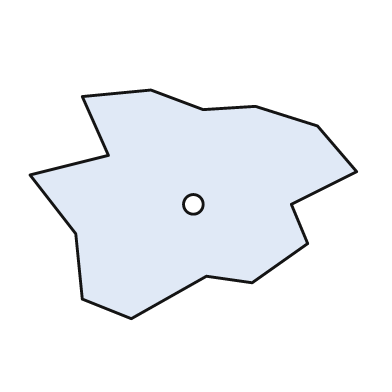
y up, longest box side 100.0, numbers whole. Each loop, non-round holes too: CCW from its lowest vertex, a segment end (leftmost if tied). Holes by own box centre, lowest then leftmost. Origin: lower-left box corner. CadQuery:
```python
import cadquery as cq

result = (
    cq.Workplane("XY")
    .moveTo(31.0, 0.0)
    .lineTo(54.0, 13.0)
    .lineTo(68.0, 11.0)
    .lineTo(85.0, 23.0)
    .lineTo(80.0, 35.0)
    .lineTo(100.0, 45.0)
    .lineTo(88.0, 59.0)
    .lineTo(69.0, 65.0)
    .lineTo(53.0, 64.0)
    .lineTo(37.0, 70.0)
    .lineTo(16.0, 68.0)
    .lineTo(24.0, 50.0)
    .lineTo(0.0, 44.0)
    .lineTo(14.0, 26.0)
    .lineTo(16.0, 6.0)
    .close()
    .moveTo(50.0, 35.0)
    .circle(3.0)
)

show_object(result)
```